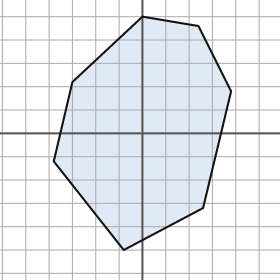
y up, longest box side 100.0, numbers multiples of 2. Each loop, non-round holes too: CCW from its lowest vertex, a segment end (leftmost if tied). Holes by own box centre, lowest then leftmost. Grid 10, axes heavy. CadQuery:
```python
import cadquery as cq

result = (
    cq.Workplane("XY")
    .moveTo(-8.0, -50.0)
    .lineTo(26.0, -32.0)
    .lineTo(38.0, 18.0)
    .lineTo(24.0, 46.0)
    .lineTo(0.0, 50.0)
    .lineTo(-30.0, 22.0)
    .lineTo(-38.0, -12.0)
    .close()
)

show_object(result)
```